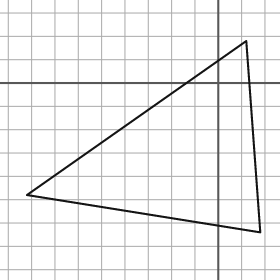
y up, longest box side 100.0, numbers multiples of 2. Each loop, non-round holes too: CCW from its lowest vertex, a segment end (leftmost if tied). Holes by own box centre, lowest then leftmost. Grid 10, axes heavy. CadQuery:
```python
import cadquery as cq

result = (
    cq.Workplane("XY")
    .moveTo(18.0, -64.0)
    .lineTo(12.0, 18.0)
    .lineTo(-82.0, -48.0)
    .close()
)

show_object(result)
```